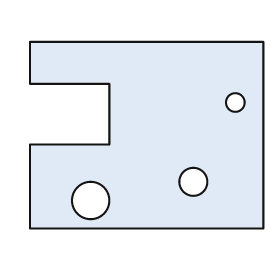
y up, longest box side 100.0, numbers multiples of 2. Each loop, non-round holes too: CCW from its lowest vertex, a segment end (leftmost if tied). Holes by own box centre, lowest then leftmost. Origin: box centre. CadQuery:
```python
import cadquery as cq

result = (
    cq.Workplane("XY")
    .moveTo(-50.0, -40.0)
    .lineTo(50.0, -40.0)
    .lineTo(50.0, 40.0)
    .lineTo(-50.0, 40.0)
    .lineTo(-50.0, 22.0)
    .lineTo(-16.0, 22.0)
    .lineTo(-16.0, -4.0)
    .lineTo(-50.0, -4.0)
    .close()
    .moveTo(-24.0, -28.0)
    .circle(8.0)
    .moveTo(20.0, -20.0)
    .circle(6.0)
    .moveTo(38.0, 14.0)
    .circle(4.0)
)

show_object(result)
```